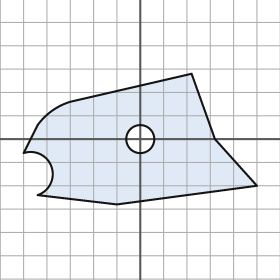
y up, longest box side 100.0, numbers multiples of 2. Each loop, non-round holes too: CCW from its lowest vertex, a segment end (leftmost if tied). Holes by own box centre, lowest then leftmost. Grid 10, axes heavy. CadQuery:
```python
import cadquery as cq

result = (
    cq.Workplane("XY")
    .moveTo(-10.0, -28.0)
    .lineTo(50.0, -20.0)
    .lineTo(32.0, 0.0)
    .lineTo(22.0, 28.0)
    .lineTo(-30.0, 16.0)
    .threePointArc((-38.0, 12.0), (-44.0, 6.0))
    .lineTo(-50.0, -6.0)
    .threePointArc((-38.0, -12.0), (-44.0, -24.0))
    .close()
    .moveTo(0.0, 0.0)
    .circle(6.0)
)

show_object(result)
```